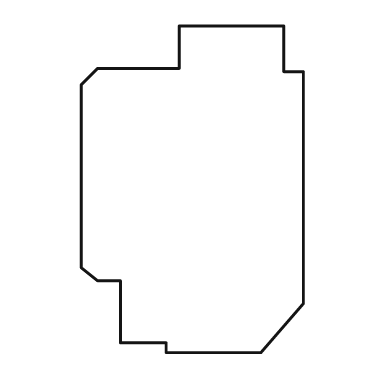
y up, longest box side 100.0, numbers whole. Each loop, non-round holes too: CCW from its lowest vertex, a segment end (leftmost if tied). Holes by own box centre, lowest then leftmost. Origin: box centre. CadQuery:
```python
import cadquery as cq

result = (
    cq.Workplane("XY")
    .moveTo(-8.0, -50.0)
    .lineTo(21.0, -50.0)
    .lineTo(34.0, -35.0)
    .lineTo(34.0, 36.0)
    .lineTo(28.0, 36.0)
    .lineTo(28.0, 50.0)
    .lineTo(-4.0, 50.0)
    .lineTo(-4.0, 37.0)
    .lineTo(-29.0, 37.0)
    .lineTo(-34.0, 32.0)
    .lineTo(-34.0, -24.0)
    .lineTo(-29.0, -28.0)
    .lineTo(-22.0, -28.0)
    .lineTo(-22.0, -47.0)
    .lineTo(-8.0, -47.0)
    .close()
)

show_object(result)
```